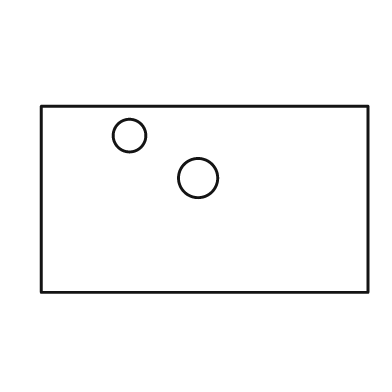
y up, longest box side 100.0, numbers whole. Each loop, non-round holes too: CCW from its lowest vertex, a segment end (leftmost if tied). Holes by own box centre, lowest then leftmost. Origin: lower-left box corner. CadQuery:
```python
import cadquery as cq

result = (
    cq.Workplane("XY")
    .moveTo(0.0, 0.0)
    .lineTo(100.0, 0.0)
    .lineTo(100.0, 57.0)
    .lineTo(0.0, 57.0)
    .close()
    .moveTo(48.0, 35.0)
    .circle(6.0)
    .moveTo(27.0, 48.0)
    .circle(5.0)
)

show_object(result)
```